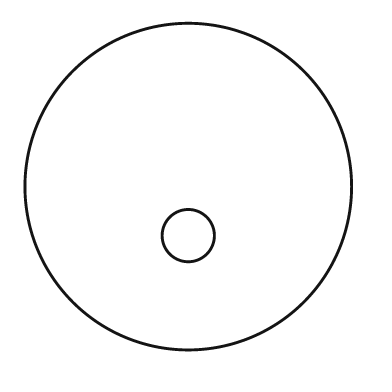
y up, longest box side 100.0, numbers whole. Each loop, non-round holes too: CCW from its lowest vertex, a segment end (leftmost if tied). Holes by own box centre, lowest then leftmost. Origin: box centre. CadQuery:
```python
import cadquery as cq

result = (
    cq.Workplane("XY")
    .moveTo(0.0, 0.0)
    .circle(50.0)
    .moveTo(0.0, -15.0)
    .circle(8.0)
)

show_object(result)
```